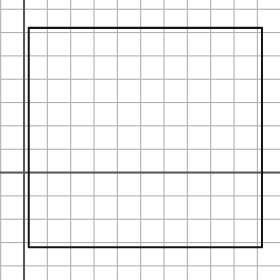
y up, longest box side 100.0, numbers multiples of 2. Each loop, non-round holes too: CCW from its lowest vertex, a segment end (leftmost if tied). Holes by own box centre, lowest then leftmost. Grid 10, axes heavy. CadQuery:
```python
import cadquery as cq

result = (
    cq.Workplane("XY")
    .moveTo(2.0, -32.0)
    .lineTo(102.0, -32.0)
    .lineTo(102.0, 62.0)
    .lineTo(2.0, 62.0)
    .close()
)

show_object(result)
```